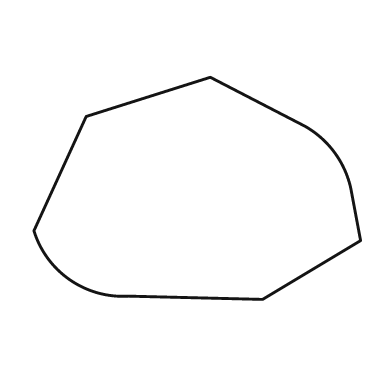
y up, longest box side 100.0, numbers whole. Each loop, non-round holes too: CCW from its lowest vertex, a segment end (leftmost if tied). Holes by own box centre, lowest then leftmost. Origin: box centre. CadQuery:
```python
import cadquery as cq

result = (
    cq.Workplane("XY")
    .moveTo(20.0, -34.0)
    .lineTo(50.0, -16.0)
    .lineTo(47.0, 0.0)
    .threePointArc((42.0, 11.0), (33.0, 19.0))
    .lineTo(4.0, 34.0)
    .lineTo(-34.0, 22.0)
    .lineTo(-50.0, -13.0)
    .threePointArc((-39.0, -28.0), (-21.0, -33.0))
    .close()
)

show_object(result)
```